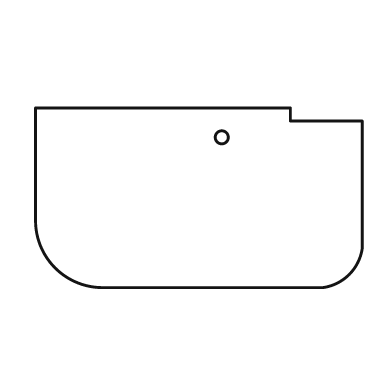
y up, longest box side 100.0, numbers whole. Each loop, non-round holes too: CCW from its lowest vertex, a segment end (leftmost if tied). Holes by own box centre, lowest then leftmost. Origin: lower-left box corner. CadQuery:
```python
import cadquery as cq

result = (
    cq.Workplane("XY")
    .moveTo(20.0, 0.0)
    .lineTo(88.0, 0.0)
    .threePointArc((96.0, 4.0), (100.0, 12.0))
    .lineTo(100.0, 51.0)
    .lineTo(78.0, 51.0)
    .lineTo(78.0, 55.0)
    .lineTo(0.0, 55.0)
    .lineTo(0.0, 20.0)
    .threePointArc((6.0, 6.0), (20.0, 0.0))
    .close()
    .moveTo(57.0, 46.0)
    .circle(2.0)
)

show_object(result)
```